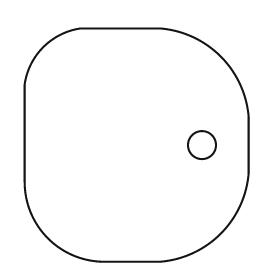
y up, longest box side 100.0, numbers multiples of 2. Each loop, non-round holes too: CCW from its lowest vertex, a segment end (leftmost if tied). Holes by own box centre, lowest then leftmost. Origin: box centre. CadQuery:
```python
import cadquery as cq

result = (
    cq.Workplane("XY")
    .moveTo(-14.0, -50.0)
    .lineTo(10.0, -50.0)
    .threePointArc((36.0, -38.0), (48.0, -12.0))
    .lineTo(48.0, 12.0)
    .threePointArc((36.0, 38.0), (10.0, 50.0))
    .lineTo(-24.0, 50.0)
    .threePointArc((-40.0, 42.0), (-48.0, 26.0))
    .lineTo(-48.0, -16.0)
    .threePointArc((-38.0, -40.0), (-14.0, -50.0))
    .close()
    .moveTo(28.0, 0.0)
    .circle(6.0)
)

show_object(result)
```